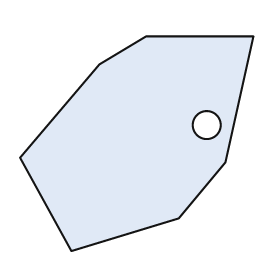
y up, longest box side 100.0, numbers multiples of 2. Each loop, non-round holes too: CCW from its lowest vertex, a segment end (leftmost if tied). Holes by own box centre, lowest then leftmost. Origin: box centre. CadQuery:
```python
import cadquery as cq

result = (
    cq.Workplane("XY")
    .moveTo(-28.0, -46.0)
    .lineTo(18.0, -32.0)
    .lineTo(38.0, -8.0)
    .lineTo(50.0, 46.0)
    .lineTo(4.0, 46.0)
    .lineTo(-16.0, 34.0)
    .lineTo(-50.0, -6.0)
    .close()
    .moveTo(30.0, 8.0)
    .circle(6.0)
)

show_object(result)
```